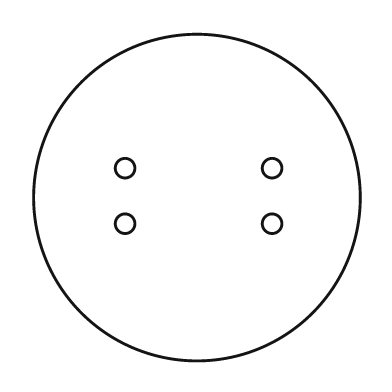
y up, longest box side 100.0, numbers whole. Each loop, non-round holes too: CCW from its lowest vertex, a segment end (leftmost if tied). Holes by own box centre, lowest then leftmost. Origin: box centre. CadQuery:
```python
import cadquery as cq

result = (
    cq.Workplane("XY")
    .moveTo(0.0, 0.0)
    .circle(50.0)
    .moveTo(-22.0, -8.0)
    .circle(3.0)
    .moveTo(23.0, -8.0)
    .circle(3.0)
    .moveTo(-22.0, 9.0)
    .circle(3.0)
    .moveTo(23.0, 9.0)
    .circle(3.0)
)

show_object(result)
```